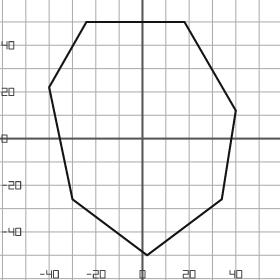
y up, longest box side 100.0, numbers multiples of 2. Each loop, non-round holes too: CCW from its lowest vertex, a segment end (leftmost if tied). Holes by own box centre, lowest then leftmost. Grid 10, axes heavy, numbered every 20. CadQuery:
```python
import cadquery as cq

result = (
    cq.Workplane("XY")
    .moveTo(2.0, -50.0)
    .lineTo(34.0, -26.0)
    .lineTo(40.0, 12.0)
    .lineTo(18.0, 50.0)
    .lineTo(-24.0, 50.0)
    .lineTo(-40.0, 22.0)
    .lineTo(-30.0, -26.0)
    .close()
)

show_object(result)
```